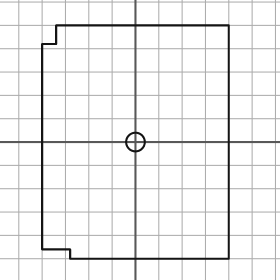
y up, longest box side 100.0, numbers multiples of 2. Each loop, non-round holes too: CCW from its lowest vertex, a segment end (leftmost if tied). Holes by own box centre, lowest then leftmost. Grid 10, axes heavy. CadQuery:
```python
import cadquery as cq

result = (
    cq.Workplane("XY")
    .moveTo(-28.0, -50.0)
    .lineTo(40.0, -50.0)
    .lineTo(40.0, 50.0)
    .lineTo(-34.0, 50.0)
    .lineTo(-34.0, 42.0)
    .lineTo(-40.0, 42.0)
    .lineTo(-40.0, -46.0)
    .lineTo(-28.0, -46.0)
    .close()
    .moveTo(0.0, 0.0)
    .circle(4.0)
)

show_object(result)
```